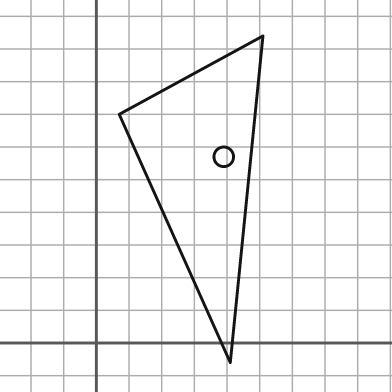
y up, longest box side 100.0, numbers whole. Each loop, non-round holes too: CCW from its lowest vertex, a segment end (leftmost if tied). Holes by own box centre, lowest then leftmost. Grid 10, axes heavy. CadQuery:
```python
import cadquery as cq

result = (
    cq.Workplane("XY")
    .moveTo(41.0, -6.0)
    .lineTo(51.0, 94.0)
    .lineTo(7.0, 70.0)
    .close()
    .moveTo(39.0, 57.0)
    .circle(3.0)
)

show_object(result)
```